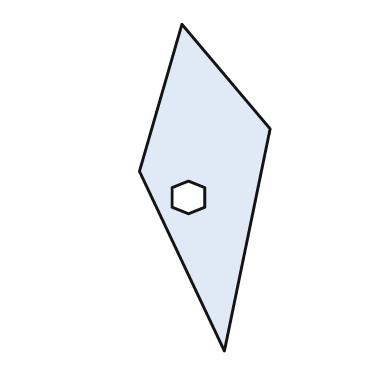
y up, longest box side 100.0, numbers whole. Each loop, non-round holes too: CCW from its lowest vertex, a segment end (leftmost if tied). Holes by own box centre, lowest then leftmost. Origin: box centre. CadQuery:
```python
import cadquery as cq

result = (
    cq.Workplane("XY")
    .moveTo(6.0, -50.0)
    .lineTo(20.0, 18.0)
    .lineTo(-7.0, 50.0)
    .lineTo(-20.0, 5.0)
    .close()
    .moveTo(-5.0, -8.0)
    .lineTo(0.0, -6.0)
    .lineTo(0.0, 0.0)
    .lineTo(-5.0, 2.0)
    .lineTo(-10.0, 0.0)
    .lineTo(-10.0, -6.0)
    .close()
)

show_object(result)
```